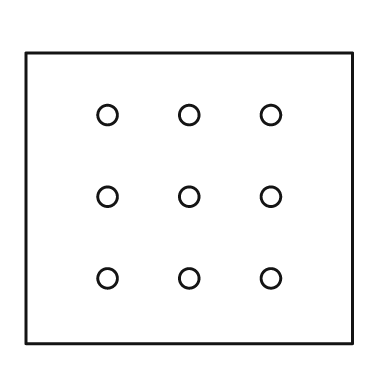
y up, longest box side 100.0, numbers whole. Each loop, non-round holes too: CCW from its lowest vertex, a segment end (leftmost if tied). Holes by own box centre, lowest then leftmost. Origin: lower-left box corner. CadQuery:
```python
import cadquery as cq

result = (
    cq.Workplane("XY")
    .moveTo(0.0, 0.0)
    .lineTo(100.0, 0.0)
    .lineTo(100.0, 89.0)
    .lineTo(0.0, 89.0)
    .close()
    .moveTo(25.0, 20.0)
    .circle(3.0)
    .moveTo(50.0, 20.0)
    .circle(3.0)
    .moveTo(75.0, 20.0)
    .circle(3.0)
    .moveTo(25.0, 45.0)
    .circle(3.0)
    .moveTo(50.0, 45.0)
    .circle(3.0)
    .moveTo(75.0, 45.0)
    .circle(3.0)
    .moveTo(25.0, 70.0)
    .circle(3.0)
    .moveTo(50.0, 70.0)
    .circle(3.0)
    .moveTo(75.0, 70.0)
    .circle(3.0)
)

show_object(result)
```